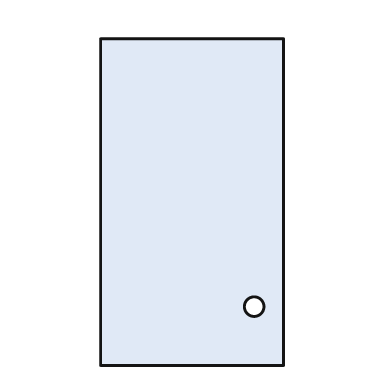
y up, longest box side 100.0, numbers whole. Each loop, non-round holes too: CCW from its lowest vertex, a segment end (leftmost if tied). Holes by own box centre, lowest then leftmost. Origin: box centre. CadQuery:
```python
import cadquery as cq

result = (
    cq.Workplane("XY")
    .moveTo(-28.0, -50.0)
    .lineTo(28.0, -50.0)
    .lineTo(28.0, 50.0)
    .lineTo(-28.0, 50.0)
    .close()
    .moveTo(19.0, -32.0)
    .circle(3.0)
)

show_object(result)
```